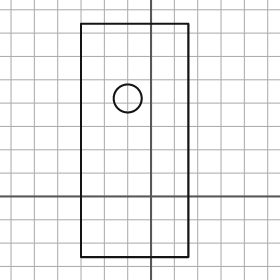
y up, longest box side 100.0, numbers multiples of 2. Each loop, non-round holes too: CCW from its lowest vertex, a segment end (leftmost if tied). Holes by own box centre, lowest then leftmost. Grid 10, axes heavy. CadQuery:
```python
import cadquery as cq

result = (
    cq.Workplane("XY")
    .moveTo(-30.0, -26.0)
    .lineTo(16.0, -26.0)
    .lineTo(16.0, 74.0)
    .lineTo(-30.0, 74.0)
    .close()
    .moveTo(-10.0, 42.0)
    .circle(6.0)
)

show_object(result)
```